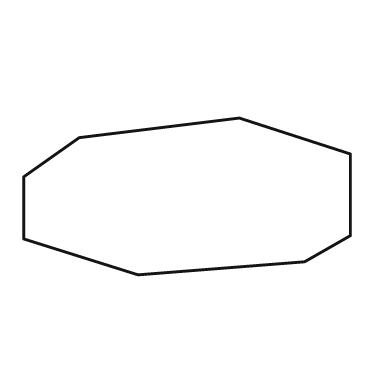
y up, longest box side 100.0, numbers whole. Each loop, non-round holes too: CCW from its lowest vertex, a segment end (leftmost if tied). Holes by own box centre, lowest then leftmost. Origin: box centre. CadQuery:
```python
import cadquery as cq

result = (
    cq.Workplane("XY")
    .moveTo(-15.0, -24.0)
    .lineTo(36.0, -20.0)
    .lineTo(50.0, -12.0)
    .lineTo(50.0, 13.0)
    .lineTo(16.0, 24.0)
    .lineTo(-33.0, 18.0)
    .lineTo(-50.0, 6.0)
    .lineTo(-50.0, -13.0)
    .close()
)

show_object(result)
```